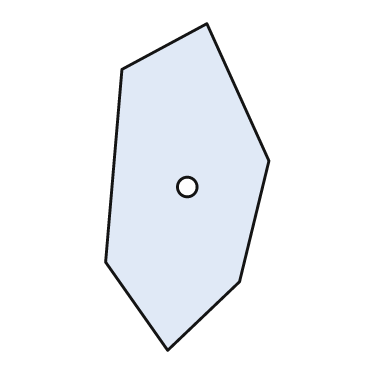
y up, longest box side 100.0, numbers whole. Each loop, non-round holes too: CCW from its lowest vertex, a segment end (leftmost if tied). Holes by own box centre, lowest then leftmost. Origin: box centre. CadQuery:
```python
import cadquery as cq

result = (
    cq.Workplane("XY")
    .moveTo(-6.0, -50.0)
    .lineTo(16.0, -29.0)
    .lineTo(25.0, 8.0)
    .lineTo(6.0, 50.0)
    .lineTo(-20.0, 36.0)
    .lineTo(-25.0, -23.0)
    .close()
    .moveTo(0.0, 0.0)
    .circle(3.0)
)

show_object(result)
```